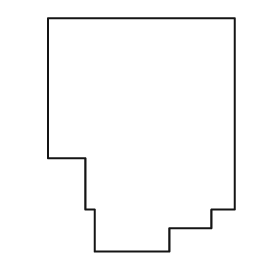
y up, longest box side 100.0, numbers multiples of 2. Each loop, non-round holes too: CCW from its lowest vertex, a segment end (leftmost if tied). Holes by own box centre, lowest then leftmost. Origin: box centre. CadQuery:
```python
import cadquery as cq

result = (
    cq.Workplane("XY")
    .moveTo(-20.0, -50.0)
    .lineTo(12.0, -50.0)
    .lineTo(12.0, -40.0)
    .lineTo(30.0, -40.0)
    .lineTo(30.0, -32.0)
    .lineTo(40.0, -32.0)
    .lineTo(40.0, 50.0)
    .lineTo(-40.0, 50.0)
    .lineTo(-40.0, -10.0)
    .lineTo(-24.0, -10.0)
    .lineTo(-24.0, -32.0)
    .lineTo(-20.0, -32.0)
    .close()
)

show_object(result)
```